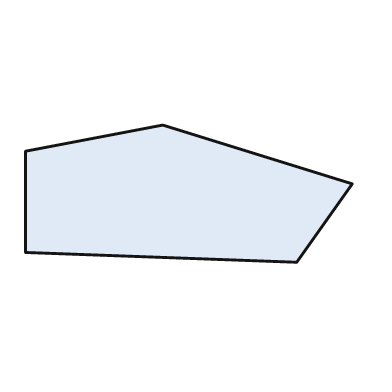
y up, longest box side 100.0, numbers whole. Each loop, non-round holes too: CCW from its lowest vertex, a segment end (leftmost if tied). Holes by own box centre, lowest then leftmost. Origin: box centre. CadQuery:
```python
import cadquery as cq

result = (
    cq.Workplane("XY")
    .moveTo(33.0, -21.0)
    .lineTo(50.0, 3.0)
    .lineTo(-8.0, 21.0)
    .lineTo(-50.0, 13.0)
    .lineTo(-50.0, -18.0)
    .close()
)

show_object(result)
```